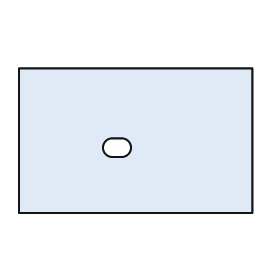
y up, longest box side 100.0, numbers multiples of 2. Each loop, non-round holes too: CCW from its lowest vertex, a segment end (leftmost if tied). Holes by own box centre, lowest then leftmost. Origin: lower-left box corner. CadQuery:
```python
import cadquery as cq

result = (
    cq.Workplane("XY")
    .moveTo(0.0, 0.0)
    .lineTo(100.0, 0.0)
    .lineTo(100.0, 62.0)
    .lineTo(0.0, 62.0)
    .close()
    .moveTo(40.0, 24.0)
    .lineTo(44.0, 24.0)
    .threePointArc((48.0, 28.0), (44.0, 32.0))
    .lineTo(40.0, 32.0)
    .threePointArc((36.0, 28.0), (40.0, 24.0))
    .close()
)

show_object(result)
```